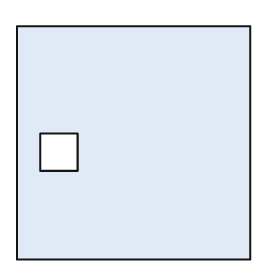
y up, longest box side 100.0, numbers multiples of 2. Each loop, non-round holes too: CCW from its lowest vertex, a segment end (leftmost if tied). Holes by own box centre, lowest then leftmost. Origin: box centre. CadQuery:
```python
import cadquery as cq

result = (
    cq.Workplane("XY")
    .moveTo(-50.0, -50.0)
    .lineTo(50.0, -50.0)
    .lineTo(50.0, 50.0)
    .lineTo(-50.0, 50.0)
    .close()
    .moveTo(-40.0, -12.0)
    .lineTo(-24.0, -12.0)
    .lineTo(-24.0, 4.0)
    .lineTo(-40.0, 4.0)
    .close()
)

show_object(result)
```